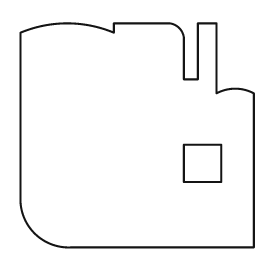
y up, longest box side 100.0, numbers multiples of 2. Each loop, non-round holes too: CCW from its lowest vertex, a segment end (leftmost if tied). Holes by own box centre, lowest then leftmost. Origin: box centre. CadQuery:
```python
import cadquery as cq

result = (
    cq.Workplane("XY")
    .moveTo(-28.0, -48.0)
    .lineTo(50.0, -48.0)
    .lineTo(50.0, 18.0)
    .threePointArc((42.0, 20.0), (34.0, 18.0))
    .lineTo(34.0, 48.0)
    .lineTo(26.0, 48.0)
    .lineTo(26.0, 24.0)
    .lineTo(20.0, 24.0)
    .lineTo(20.0, 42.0)
    .threePointArc((18.0, 46.0), (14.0, 48.0))
    .lineTo(-10.0, 48.0)
    .lineTo(-10.0, 44.0)
    .threePointArc((-30.0, 48.0), (-50.0, 44.0))
    .lineTo(-50.0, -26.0)
    .threePointArc((-44.0, -42.0), (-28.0, -48.0))
    .close()
    .moveTo(20.0, -20.0)
    .lineTo(36.0, -20.0)
    .lineTo(36.0, -4.0)
    .lineTo(20.0, -4.0)
    .close()
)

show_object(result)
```